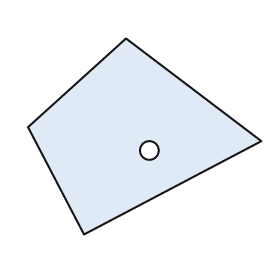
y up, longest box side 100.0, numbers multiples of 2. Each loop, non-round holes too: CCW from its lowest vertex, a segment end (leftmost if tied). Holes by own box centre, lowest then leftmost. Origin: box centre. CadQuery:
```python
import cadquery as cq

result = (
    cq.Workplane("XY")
    .moveTo(-26.0, -42.0)
    .lineTo(50.0, -2.0)
    .lineTo(-8.0, 42.0)
    .lineTo(-50.0, 4.0)
    .close()
    .moveTo(2.0, -6.0)
    .circle(4.0)
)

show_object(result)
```